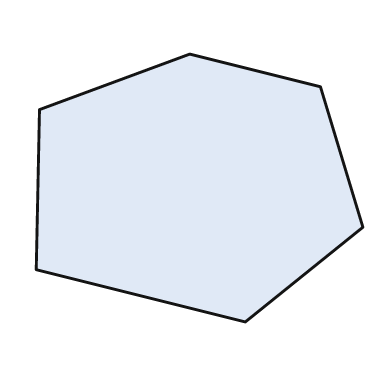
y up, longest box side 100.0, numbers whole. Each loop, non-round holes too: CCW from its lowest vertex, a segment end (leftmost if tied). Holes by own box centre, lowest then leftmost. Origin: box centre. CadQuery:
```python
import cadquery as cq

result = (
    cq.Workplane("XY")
    .moveTo(14.0, -41.0)
    .lineTo(50.0, -12.0)
    .lineTo(37.0, 31.0)
    .lineTo(-3.0, 41.0)
    .lineTo(-49.0, 24.0)
    .lineTo(-50.0, -25.0)
    .close()
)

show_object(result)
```